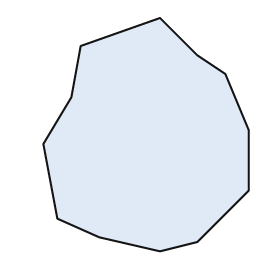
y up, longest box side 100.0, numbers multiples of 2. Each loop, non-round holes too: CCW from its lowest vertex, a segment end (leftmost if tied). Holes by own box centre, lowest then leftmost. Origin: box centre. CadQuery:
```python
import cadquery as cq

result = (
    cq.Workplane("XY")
    .moveTo(6.0, -50.0)
    .lineTo(22.0, -46.0)
    .lineTo(44.0, -24.0)
    .lineTo(44.0, 2.0)
    .lineTo(34.0, 26.0)
    .lineTo(22.0, 34.0)
    .lineTo(6.0, 50.0)
    .lineTo(-28.0, 38.0)
    .lineTo(-32.0, 16.0)
    .lineTo(-44.0, -4.0)
    .lineTo(-38.0, -36.0)
    .lineTo(-20.0, -44.0)
    .close()
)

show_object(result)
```